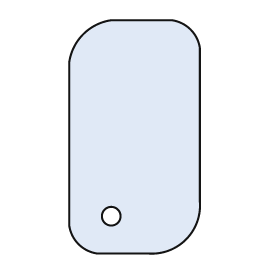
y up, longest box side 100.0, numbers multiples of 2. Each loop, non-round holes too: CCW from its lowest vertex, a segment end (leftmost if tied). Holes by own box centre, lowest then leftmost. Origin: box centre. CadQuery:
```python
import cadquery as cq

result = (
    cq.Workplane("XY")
    .moveTo(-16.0, -50.0)
    .lineTo(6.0, -50.0)
    .threePointArc((22.0, -44.0), (28.0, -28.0))
    .lineTo(28.0, 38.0)
    .threePointArc((24.0, 46.0), (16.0, 50.0))
    .lineTo(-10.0, 50.0)
    .threePointArc((-22.0, 44.0), (-28.0, 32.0))
    .lineTo(-28.0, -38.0)
    .threePointArc((-24.0, -46.0), (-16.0, -50.0))
    .close()
    .moveTo(-10.0, -34.0)
    .circle(4.0)
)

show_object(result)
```